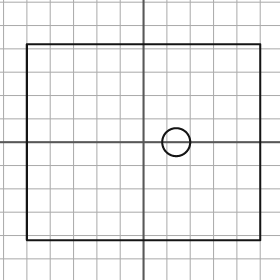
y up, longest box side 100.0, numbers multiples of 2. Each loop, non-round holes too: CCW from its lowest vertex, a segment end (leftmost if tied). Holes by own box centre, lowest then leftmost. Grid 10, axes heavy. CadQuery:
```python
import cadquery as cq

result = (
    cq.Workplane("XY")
    .moveTo(-50.0, -42.0)
    .lineTo(50.0, -42.0)
    .lineTo(50.0, 42.0)
    .lineTo(-50.0, 42.0)
    .close()
    .moveTo(14.0, 0.0)
    .circle(6.0)
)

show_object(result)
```